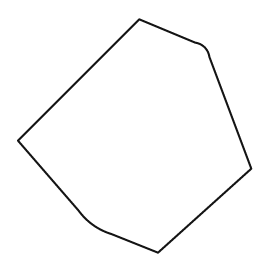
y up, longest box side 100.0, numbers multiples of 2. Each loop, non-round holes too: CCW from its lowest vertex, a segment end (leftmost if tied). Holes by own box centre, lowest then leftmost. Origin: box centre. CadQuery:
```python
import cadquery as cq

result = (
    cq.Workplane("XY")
    .moveTo(10.0, -50.0)
    .lineTo(50.0, -14.0)
    .lineTo(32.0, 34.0)
    .threePointArc((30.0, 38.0), (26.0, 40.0))
    .lineTo(2.0, 50.0)
    .lineTo(-50.0, -2.0)
    .lineTo(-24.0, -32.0)
    .threePointArc((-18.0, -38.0), (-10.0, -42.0))
    .close()
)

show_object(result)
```